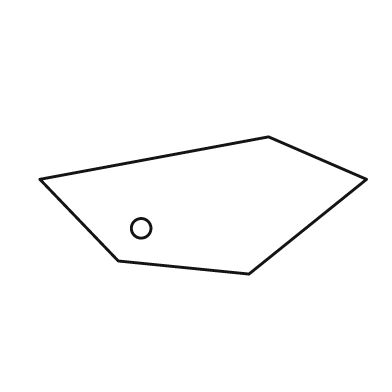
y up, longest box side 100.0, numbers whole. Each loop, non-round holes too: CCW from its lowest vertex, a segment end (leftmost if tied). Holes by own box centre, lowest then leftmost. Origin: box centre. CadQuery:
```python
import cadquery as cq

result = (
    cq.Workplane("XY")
    .moveTo(14.0, -21.0)
    .lineTo(50.0, 8.0)
    .lineTo(20.0, 21.0)
    .lineTo(-50.0, 8.0)
    .lineTo(-26.0, -17.0)
    .close()
    .moveTo(-19.0, -7.0)
    .circle(3.0)
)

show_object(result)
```